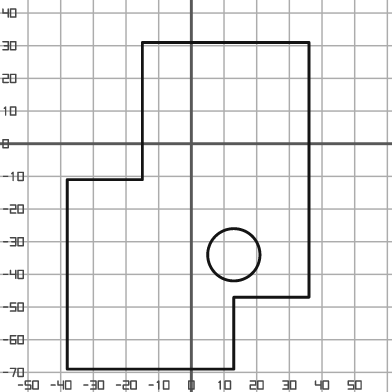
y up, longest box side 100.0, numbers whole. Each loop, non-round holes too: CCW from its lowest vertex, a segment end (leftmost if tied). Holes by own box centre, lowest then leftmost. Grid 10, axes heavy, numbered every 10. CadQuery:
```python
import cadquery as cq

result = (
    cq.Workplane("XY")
    .moveTo(-38.0, -69.0)
    .lineTo(13.0, -69.0)
    .lineTo(13.0, -47.0)
    .lineTo(36.0, -47.0)
    .lineTo(36.0, 31.0)
    .lineTo(-15.0, 31.0)
    .lineTo(-15.0, -11.0)
    .lineTo(-38.0, -11.0)
    .close()
    .moveTo(13.0, -34.0)
    .circle(8.0)
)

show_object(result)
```